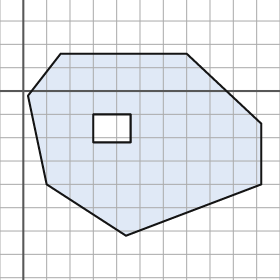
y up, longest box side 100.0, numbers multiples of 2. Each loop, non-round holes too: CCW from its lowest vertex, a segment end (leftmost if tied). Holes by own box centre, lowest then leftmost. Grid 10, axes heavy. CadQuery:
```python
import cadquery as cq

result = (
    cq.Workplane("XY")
    .moveTo(44.0, -62.0)
    .lineTo(102.0, -40.0)
    .lineTo(102.0, -14.0)
    .lineTo(70.0, 16.0)
    .lineTo(16.0, 16.0)
    .lineTo(2.0, -2.0)
    .lineTo(10.0, -40.0)
    .close()
    .moveTo(30.0, -22.0)
    .lineTo(46.0, -22.0)
    .lineTo(46.0, -10.0)
    .lineTo(30.0, -10.0)
    .close()
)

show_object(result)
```